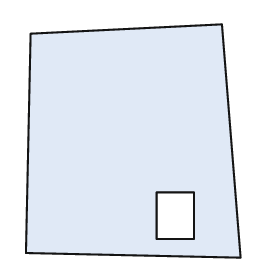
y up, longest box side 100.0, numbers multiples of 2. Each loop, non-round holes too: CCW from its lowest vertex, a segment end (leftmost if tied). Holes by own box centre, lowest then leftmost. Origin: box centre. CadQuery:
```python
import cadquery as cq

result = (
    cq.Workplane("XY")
    .moveTo(46.0, -50.0)
    .lineTo(38.0, 50.0)
    .lineTo(-44.0, 46.0)
    .lineTo(-46.0, -48.0)
    .close()
    .moveTo(10.0, -42.0)
    .lineTo(26.0, -42.0)
    .lineTo(26.0, -22.0)
    .lineTo(10.0, -22.0)
    .close()
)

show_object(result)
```